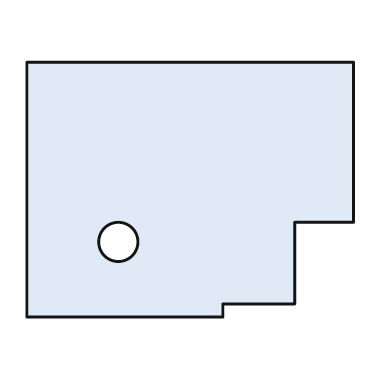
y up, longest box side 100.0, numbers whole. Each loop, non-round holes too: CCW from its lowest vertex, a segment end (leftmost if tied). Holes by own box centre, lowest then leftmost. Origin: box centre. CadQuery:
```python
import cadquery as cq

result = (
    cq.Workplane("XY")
    .moveTo(-50.0, -39.0)
    .lineTo(10.0, -39.0)
    .lineTo(10.0, -35.0)
    .lineTo(32.0, -35.0)
    .lineTo(32.0, -10.0)
    .lineTo(50.0, -10.0)
    .lineTo(50.0, 39.0)
    .lineTo(-50.0, 39.0)
    .close()
    .moveTo(-22.0, -16.0)
    .circle(6.0)
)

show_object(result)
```